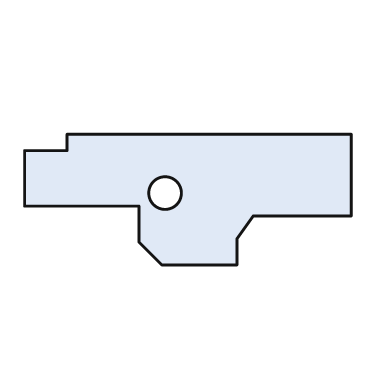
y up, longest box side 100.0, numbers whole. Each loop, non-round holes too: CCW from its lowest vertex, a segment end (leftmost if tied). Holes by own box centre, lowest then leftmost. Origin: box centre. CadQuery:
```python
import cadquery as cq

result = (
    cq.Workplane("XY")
    .moveTo(-8.0, -20.0)
    .lineTo(15.0, -20.0)
    .lineTo(15.0, -12.0)
    .lineTo(20.0, -5.0)
    .lineTo(50.0, -5.0)
    .lineTo(50.0, 20.0)
    .lineTo(-37.0, 20.0)
    .lineTo(-37.0, 15.0)
    .lineTo(-50.0, 15.0)
    .lineTo(-50.0, -2.0)
    .lineTo(-15.0, -2.0)
    .lineTo(-15.0, -13.0)
    .close()
    .moveTo(-7.0, 2.0)
    .circle(5.0)
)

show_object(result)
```